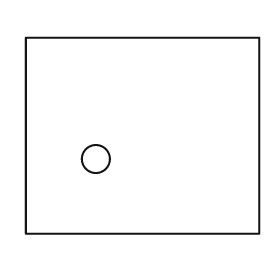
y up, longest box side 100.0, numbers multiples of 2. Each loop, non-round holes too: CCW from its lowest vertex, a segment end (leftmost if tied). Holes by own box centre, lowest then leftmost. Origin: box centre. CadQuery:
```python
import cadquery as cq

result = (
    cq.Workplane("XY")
    .moveTo(-50.0, -42.0)
    .lineTo(50.0, -42.0)
    .lineTo(50.0, 42.0)
    .lineTo(-50.0, 42.0)
    .close()
    .moveTo(-20.0, -10.0)
    .circle(6.0)
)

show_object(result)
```